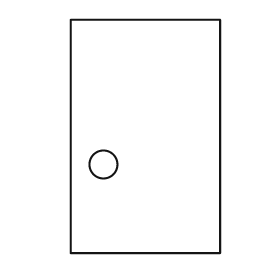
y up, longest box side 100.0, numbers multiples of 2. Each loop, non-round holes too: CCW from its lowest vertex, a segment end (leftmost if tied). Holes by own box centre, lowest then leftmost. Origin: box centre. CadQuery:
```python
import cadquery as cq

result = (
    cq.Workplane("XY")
    .moveTo(-32.0, -50.0)
    .lineTo(32.0, -50.0)
    .lineTo(32.0, 50.0)
    .lineTo(-32.0, 50.0)
    .close()
    .moveTo(-18.0, -12.0)
    .circle(6.0)
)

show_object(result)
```